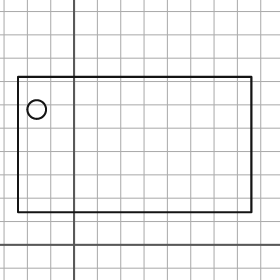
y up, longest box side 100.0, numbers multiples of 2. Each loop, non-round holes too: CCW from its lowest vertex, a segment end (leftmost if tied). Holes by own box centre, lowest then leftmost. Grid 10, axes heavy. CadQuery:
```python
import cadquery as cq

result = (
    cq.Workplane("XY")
    .moveTo(-24.0, 14.0)
    .lineTo(76.0, 14.0)
    .lineTo(76.0, 72.0)
    .lineTo(-24.0, 72.0)
    .close()
    .moveTo(-16.0, 58.0)
    .circle(4.0)
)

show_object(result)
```